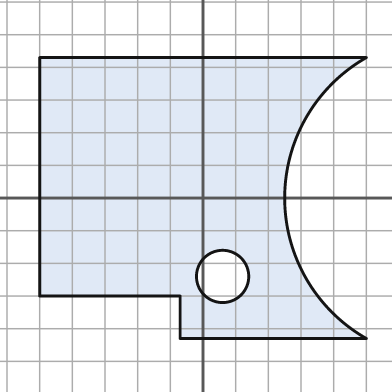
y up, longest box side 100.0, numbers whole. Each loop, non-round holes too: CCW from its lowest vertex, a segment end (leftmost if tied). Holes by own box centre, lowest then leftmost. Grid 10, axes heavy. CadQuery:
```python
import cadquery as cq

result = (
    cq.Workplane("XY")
    .moveTo(-7.0, -43.0)
    .lineTo(50.0, -43.0)
    .threePointArc((25.0, 0.0), (50.0, 43.0))
    .lineTo(-50.0, 43.0)
    .lineTo(-50.0, -30.0)
    .lineTo(-7.0, -30.0)
    .close()
    .moveTo(6.0, -24.0)
    .circle(8.0)
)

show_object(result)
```